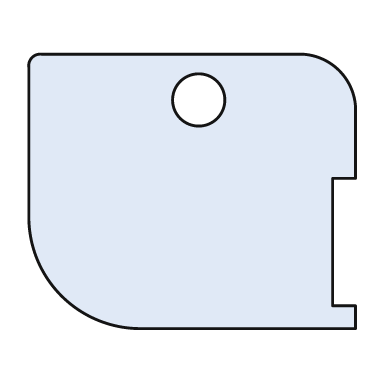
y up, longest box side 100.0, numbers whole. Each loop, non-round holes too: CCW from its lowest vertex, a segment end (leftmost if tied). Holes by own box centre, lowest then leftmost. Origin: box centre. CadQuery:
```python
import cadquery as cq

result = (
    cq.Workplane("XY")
    .moveTo(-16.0, -42.0)
    .lineTo(50.0, -42.0)
    .lineTo(50.0, -35.0)
    .lineTo(43.0, -35.0)
    .lineTo(43.0, 4.0)
    .lineTo(50.0, 4.0)
    .lineTo(50.0, 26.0)
    .threePointArc((45.0, 37.0), (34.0, 42.0))
    .lineTo(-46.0, 42.0)
    .threePointArc((-49.0, 41.0), (-50.0, 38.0))
    .lineTo(-50.0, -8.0)
    .threePointArc((-40.0, -32.0), (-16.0, -42.0))
    .close()
    .moveTo(2.0, 28.0)
    .circle(8.0)
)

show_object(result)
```